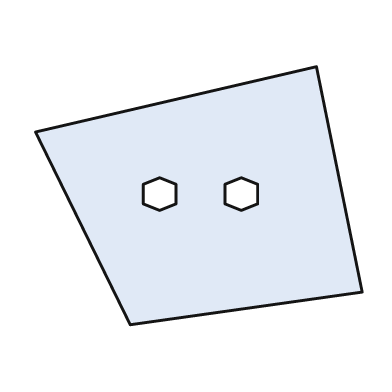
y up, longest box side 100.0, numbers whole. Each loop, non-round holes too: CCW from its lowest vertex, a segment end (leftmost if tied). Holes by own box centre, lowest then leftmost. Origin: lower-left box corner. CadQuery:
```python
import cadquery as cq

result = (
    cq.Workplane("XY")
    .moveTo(29.0, 0.0)
    .lineTo(100.0, 10.0)
    .lineTo(86.0, 79.0)
    .lineTo(0.0, 59.0)
    .close()
    .moveTo(38.0, 35.0)
    .lineTo(43.0, 37.0)
    .lineTo(43.0, 43.0)
    .lineTo(38.0, 45.0)
    .lineTo(33.0, 43.0)
    .lineTo(33.0, 37.0)
    .close()
    .moveTo(63.0, 35.0)
    .lineTo(68.0, 37.0)
    .lineTo(68.0, 43.0)
    .lineTo(63.0, 45.0)
    .lineTo(58.0, 43.0)
    .lineTo(58.0, 37.0)
    .close()
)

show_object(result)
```